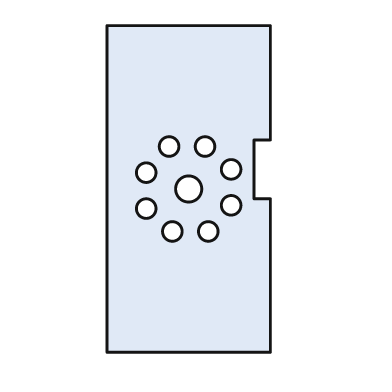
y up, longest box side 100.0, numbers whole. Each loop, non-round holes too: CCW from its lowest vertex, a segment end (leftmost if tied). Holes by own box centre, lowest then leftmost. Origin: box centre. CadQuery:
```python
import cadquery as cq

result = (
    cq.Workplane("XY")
    .moveTo(-25.0, -50.0)
    .lineTo(25.0, -50.0)
    .lineTo(25.0, -3.0)
    .lineTo(20.0, -3.0)
    .lineTo(20.0, 15.0)
    .lineTo(25.0, 15.0)
    .lineTo(25.0, 50.0)
    .lineTo(-25.0, 50.0)
    .close()
    .moveTo(-5.0, -13.0)
    .circle(3.0)
    .moveTo(6.0, -13.0)
    .circle(3.0)
    .moveTo(-13.0, -6.0)
    .circle(3.0)
    .moveTo(13.0, -5.0)
    .circle(3.0)
    .moveTo(0.0, 0.0)
    .circle(4.0)
    .moveTo(-13.0, 5.0)
    .circle(3.0)
    .moveTo(13.0, 6.0)
    .circle(3.0)
    .moveTo(-6.0, 13.0)
    .circle(3.0)
    .moveTo(5.0, 13.0)
    .circle(3.0)
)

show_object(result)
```